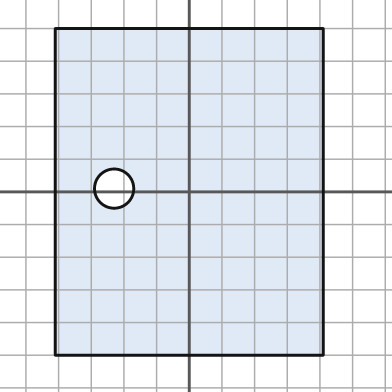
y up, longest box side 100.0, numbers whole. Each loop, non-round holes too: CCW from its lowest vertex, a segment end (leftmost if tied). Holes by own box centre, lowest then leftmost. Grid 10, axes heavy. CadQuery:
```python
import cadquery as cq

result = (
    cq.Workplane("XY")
    .moveTo(-41.0, -50.0)
    .lineTo(41.0, -50.0)
    .lineTo(41.0, 50.0)
    .lineTo(-41.0, 50.0)
    .close()
    .moveTo(-23.0, 1.0)
    .circle(6.0)
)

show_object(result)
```